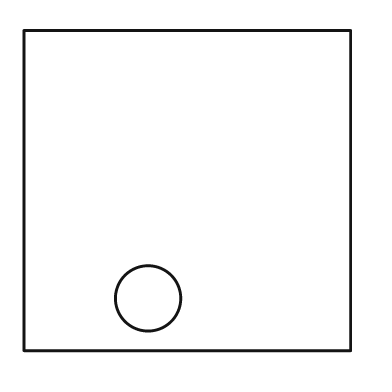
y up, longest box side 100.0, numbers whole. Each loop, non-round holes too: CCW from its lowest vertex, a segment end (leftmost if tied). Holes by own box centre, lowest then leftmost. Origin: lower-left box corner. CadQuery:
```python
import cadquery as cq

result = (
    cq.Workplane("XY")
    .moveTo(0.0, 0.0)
    .lineTo(100.0, 0.0)
    .lineTo(100.0, 98.0)
    .lineTo(0.0, 98.0)
    .close()
    .moveTo(38.0, 16.0)
    .circle(10.0)
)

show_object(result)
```